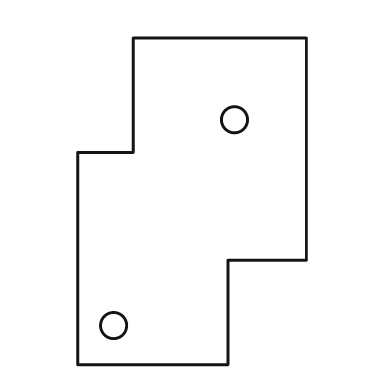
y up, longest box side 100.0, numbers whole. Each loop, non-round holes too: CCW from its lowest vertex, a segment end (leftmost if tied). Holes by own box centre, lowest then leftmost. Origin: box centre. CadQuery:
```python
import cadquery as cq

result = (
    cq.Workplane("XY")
    .moveTo(-35.0, -50.0)
    .lineTo(11.0, -50.0)
    .lineTo(11.0, -18.0)
    .lineTo(35.0, -18.0)
    .lineTo(35.0, 50.0)
    .lineTo(-18.0, 50.0)
    .lineTo(-18.0, 15.0)
    .lineTo(-35.0, 15.0)
    .close()
    .moveTo(-24.0, -38.0)
    .circle(4.0)
    .moveTo(13.0, 25.0)
    .circle(4.0)
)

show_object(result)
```